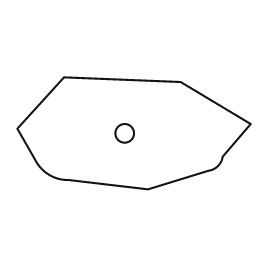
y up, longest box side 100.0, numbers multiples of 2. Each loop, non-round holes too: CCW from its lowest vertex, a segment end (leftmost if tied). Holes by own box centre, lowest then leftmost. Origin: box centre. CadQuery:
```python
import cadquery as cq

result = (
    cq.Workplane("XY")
    .moveTo(6.0, -24.0)
    .lineTo(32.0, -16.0)
    .threePointArc((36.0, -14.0), (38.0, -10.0))
    .lineTo(50.0, 4.0)
    .lineTo(20.0, 22.0)
    .lineTo(-30.0, 24.0)
    .lineTo(-50.0, 2.0)
    .lineTo(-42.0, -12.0)
    .threePointArc((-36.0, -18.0), (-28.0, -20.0))
    .close()
    .moveTo(-4.0, 0.0)
    .circle(4.0)
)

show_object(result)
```